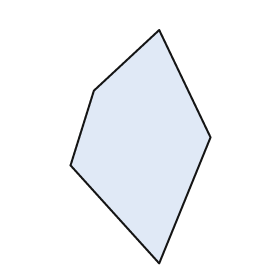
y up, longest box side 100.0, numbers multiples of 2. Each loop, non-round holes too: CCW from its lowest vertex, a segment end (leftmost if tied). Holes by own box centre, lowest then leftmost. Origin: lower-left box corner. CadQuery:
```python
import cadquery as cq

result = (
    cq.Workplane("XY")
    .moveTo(38.0, 0.0)
    .lineTo(60.0, 54.0)
    .lineTo(38.0, 100.0)
    .lineTo(10.0, 74.0)
    .lineTo(0.0, 42.0)
    .close()
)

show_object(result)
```